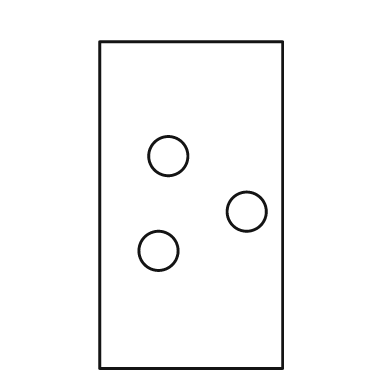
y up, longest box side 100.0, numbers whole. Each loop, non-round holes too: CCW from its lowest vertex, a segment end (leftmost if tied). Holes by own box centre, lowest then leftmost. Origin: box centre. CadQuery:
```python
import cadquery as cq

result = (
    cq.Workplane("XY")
    .moveTo(-28.0, -50.0)
    .lineTo(28.0, -50.0)
    .lineTo(28.0, 50.0)
    .lineTo(-28.0, 50.0)
    .close()
    .moveTo(-10.0, -14.0)
    .circle(6.0)
    .moveTo(17.0, -2.0)
    .circle(6.0)
    .moveTo(-7.0, 15.0)
    .circle(6.0)
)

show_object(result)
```